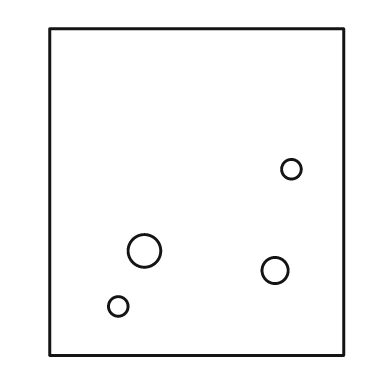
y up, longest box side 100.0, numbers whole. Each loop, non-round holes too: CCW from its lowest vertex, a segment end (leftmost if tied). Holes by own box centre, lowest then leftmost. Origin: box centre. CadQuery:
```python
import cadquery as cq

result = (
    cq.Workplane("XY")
    .moveTo(-45.0, -50.0)
    .lineTo(45.0, -50.0)
    .lineTo(45.0, 50.0)
    .lineTo(-45.0, 50.0)
    .close()
    .moveTo(-24.0, -35.0)
    .circle(3.0)
    .moveTo(24.0, -24.0)
    .circle(4.0)
    .moveTo(-16.0, -18.0)
    .circle(5.0)
    .moveTo(29.0, 7.0)
    .circle(3.0)
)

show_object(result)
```